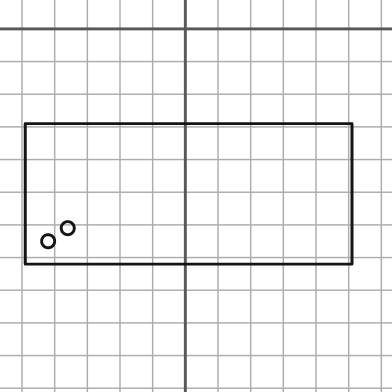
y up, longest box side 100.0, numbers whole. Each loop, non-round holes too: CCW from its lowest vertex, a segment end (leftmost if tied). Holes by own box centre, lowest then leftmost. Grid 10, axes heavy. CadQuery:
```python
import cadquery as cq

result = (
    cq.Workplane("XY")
    .moveTo(-49.0, -72.0)
    .lineTo(51.0, -72.0)
    .lineTo(51.0, -29.0)
    .lineTo(-49.0, -29.0)
    .close()
    .moveTo(-42.0, -65.0)
    .circle(2.0)
    .moveTo(-36.0, -61.0)
    .circle(2.0)
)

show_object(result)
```